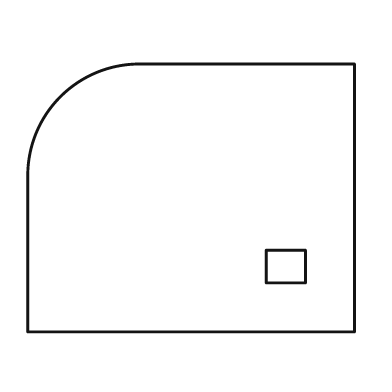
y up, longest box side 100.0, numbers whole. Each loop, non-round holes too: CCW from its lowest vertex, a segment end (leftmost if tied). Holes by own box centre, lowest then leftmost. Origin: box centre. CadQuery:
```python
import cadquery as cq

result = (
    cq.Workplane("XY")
    .moveTo(-50.0, -41.0)
    .lineTo(50.0, -41.0)
    .lineTo(50.0, 41.0)
    .lineTo(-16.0, 41.0)
    .threePointArc((-40.0, 31.0), (-50.0, 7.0))
    .close()
    .moveTo(23.0, -26.0)
    .lineTo(35.0, -26.0)
    .lineTo(35.0, -16.0)
    .lineTo(23.0, -16.0)
    .close()
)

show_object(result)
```